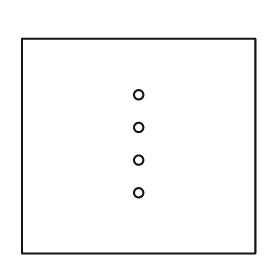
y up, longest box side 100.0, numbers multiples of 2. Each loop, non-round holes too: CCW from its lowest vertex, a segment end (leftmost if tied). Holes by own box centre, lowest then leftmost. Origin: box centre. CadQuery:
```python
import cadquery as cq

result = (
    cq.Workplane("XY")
    .moveTo(-50.0, -46.0)
    .lineTo(50.0, -46.0)
    .lineTo(50.0, 46.0)
    .lineTo(-50.0, 46.0)
    .close()
    .moveTo(0.0, -20.0)
    .circle(2.0)
    .moveTo(0.0, -6.0)
    .circle(2.0)
    .moveTo(0.0, 8.0)
    .circle(2.0)
    .moveTo(0.0, 22.0)
    .circle(2.0)
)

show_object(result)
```